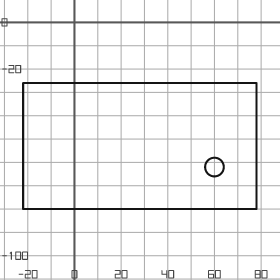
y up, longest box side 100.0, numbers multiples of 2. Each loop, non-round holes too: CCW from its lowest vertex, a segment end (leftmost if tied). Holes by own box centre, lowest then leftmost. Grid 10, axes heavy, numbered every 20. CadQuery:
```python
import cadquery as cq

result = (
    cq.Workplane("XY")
    .moveTo(-22.0, -80.0)
    .lineTo(78.0, -80.0)
    .lineTo(78.0, -26.0)
    .lineTo(-22.0, -26.0)
    .close()
    .moveTo(60.0, -62.0)
    .circle(4.0)
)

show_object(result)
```